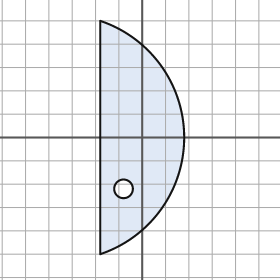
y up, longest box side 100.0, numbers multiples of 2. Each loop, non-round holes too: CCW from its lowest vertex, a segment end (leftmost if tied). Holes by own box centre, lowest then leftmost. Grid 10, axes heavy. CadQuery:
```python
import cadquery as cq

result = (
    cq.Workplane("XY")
    .moveTo(-18.0, -50.0)
    .threePointArc((18.0, 0.0), (-18.0, 50.0))
    .close()
    .moveTo(-8.0, -22.0)
    .circle(4.0)
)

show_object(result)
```